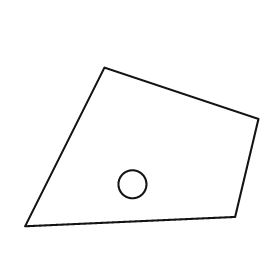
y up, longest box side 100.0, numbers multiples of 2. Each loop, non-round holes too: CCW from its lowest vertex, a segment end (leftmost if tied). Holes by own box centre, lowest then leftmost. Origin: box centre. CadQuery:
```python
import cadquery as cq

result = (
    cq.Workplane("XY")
    .moveTo(-50.0, -34.0)
    .lineTo(40.0, -30.0)
    .lineTo(50.0, 12.0)
    .lineTo(-16.0, 34.0)
    .close()
    .moveTo(-4.0, -16.0)
    .circle(6.0)
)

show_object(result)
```